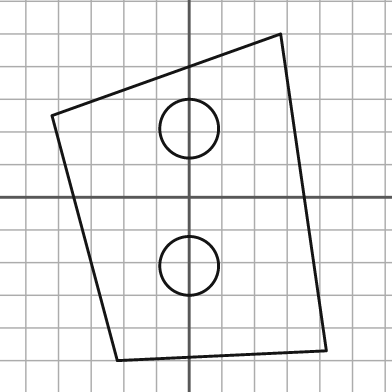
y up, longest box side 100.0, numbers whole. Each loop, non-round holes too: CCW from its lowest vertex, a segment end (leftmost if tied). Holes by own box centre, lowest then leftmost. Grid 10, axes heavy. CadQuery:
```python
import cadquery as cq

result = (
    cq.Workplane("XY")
    .moveTo(-22.0, -50.0)
    .lineTo(42.0, -47.0)
    .lineTo(28.0, 50.0)
    .lineTo(-42.0, 25.0)
    .close()
    .moveTo(0.0, -21.0)
    .circle(9.0)
    .moveTo(0.0, 21.0)
    .circle(9.0)
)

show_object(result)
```